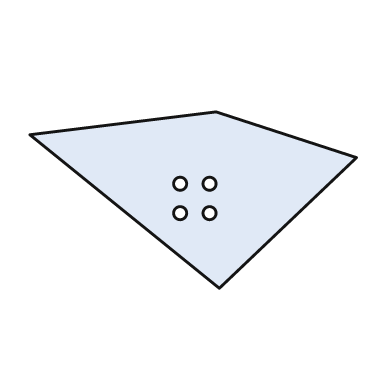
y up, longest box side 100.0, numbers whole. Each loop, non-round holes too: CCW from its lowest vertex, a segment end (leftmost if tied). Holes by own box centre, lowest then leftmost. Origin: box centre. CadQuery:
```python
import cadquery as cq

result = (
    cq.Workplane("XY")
    .moveTo(8.0, -27.0)
    .lineTo(50.0, 13.0)
    .lineTo(7.0, 27.0)
    .lineTo(-50.0, 20.0)
    .close()
    .moveTo(-4.0, -4.0)
    .circle(2.0)
    .moveTo(5.0, -4.0)
    .circle(2.0)
    .moveTo(-4.0, 5.0)
    .circle(2.0)
    .moveTo(5.0, 5.0)
    .circle(2.0)
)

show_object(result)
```